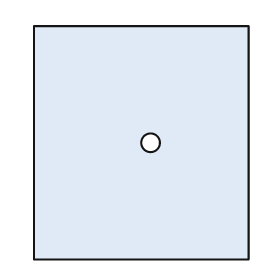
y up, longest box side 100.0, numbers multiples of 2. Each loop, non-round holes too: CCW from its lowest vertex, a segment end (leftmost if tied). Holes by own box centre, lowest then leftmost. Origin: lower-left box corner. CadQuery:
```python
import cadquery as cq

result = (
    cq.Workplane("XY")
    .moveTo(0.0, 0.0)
    .lineTo(92.0, 0.0)
    .lineTo(92.0, 100.0)
    .lineTo(0.0, 100.0)
    .close()
    .moveTo(50.0, 50.0)
    .circle(4.0)
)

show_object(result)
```